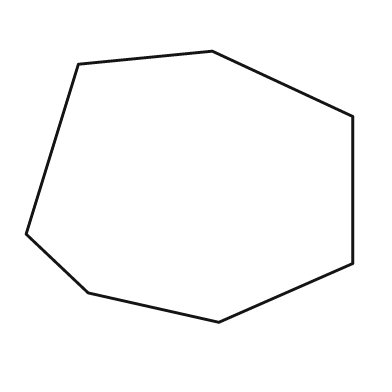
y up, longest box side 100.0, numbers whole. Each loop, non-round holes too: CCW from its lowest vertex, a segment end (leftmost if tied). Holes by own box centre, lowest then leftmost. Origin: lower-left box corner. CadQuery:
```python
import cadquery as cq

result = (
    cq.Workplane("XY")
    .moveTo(59.0, 0.0)
    .lineTo(100.0, 18.0)
    .lineTo(100.0, 63.0)
    .lineTo(57.0, 83.0)
    .lineTo(16.0, 79.0)
    .lineTo(0.0, 27.0)
    .lineTo(19.0, 9.0)
    .close()
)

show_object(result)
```